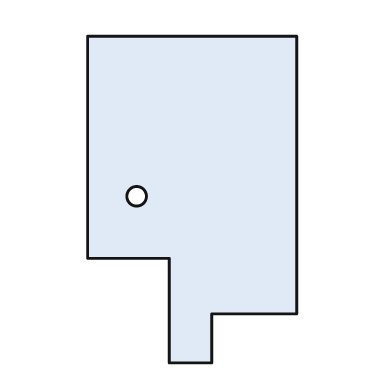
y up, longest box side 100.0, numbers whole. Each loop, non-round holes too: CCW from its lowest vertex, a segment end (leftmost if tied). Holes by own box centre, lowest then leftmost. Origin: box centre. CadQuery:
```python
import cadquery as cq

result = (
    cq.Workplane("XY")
    .moveTo(-7.0, -50.0)
    .lineTo(6.0, -50.0)
    .lineTo(6.0, -35.0)
    .lineTo(32.0, -35.0)
    .lineTo(32.0, 50.0)
    .lineTo(-32.0, 50.0)
    .lineTo(-32.0, -18.0)
    .lineTo(-7.0, -18.0)
    .close()
    .moveTo(-17.0, 1.0)
    .circle(3.0)
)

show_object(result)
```